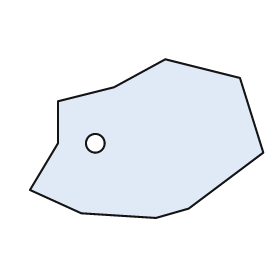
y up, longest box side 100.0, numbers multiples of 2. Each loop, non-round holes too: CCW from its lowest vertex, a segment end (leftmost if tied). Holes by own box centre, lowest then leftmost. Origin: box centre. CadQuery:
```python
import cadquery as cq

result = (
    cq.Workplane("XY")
    .moveTo(4.0, -34.0)
    .lineTo(18.0, -30.0)
    .lineTo(50.0, -6.0)
    .lineTo(40.0, 26.0)
    .lineTo(8.0, 34.0)
    .lineTo(-14.0, 22.0)
    .lineTo(-38.0, 16.0)
    .lineTo(-38.0, -2.0)
    .lineTo(-50.0, -22.0)
    .lineTo(-28.0, -32.0)
    .close()
    .moveTo(-22.0, -2.0)
    .circle(4.0)
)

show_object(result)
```